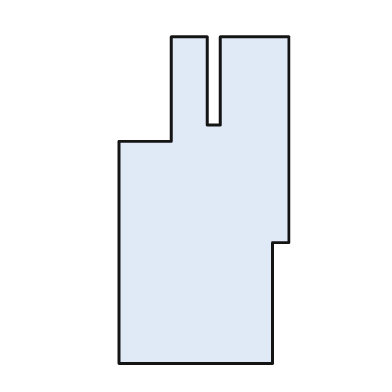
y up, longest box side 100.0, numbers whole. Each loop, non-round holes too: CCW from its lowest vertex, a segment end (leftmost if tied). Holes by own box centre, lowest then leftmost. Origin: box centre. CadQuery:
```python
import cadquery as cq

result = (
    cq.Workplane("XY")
    .moveTo(-26.0, -50.0)
    .lineTo(21.0, -50.0)
    .lineTo(21.0, -13.0)
    .lineTo(26.0, -13.0)
    .lineTo(26.0, 50.0)
    .lineTo(5.0, 50.0)
    .lineTo(5.0, 23.0)
    .lineTo(1.0, 23.0)
    .lineTo(1.0, 50.0)
    .lineTo(-10.0, 50.0)
    .lineTo(-10.0, 18.0)
    .lineTo(-26.0, 18.0)
    .close()
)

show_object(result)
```